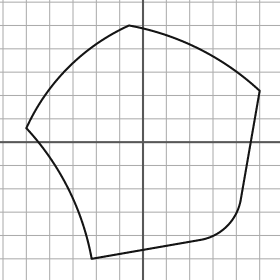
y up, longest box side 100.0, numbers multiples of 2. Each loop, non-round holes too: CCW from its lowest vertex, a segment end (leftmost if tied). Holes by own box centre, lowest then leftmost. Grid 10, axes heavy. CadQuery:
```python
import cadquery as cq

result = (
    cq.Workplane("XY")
    .moveTo(-22.0, -50.0)
    .lineTo(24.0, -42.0)
    .threePointArc((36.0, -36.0), (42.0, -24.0))
    .lineTo(50.0, 22.0)
    .threePointArc((24.0, 40.0), (-6.0, 50.0))
    .threePointArc((-32.0, 32.0), (-50.0, 6.0))
    .threePointArc((-32.0, -20.0), (-22.0, -50.0))
    .close()
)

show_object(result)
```